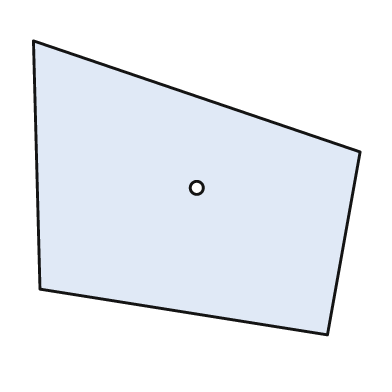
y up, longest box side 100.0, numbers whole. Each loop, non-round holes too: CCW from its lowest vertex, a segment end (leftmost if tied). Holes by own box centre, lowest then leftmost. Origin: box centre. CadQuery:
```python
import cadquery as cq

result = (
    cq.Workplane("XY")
    .moveTo(40.0, -45.0)
    .lineTo(50.0, 11.0)
    .lineTo(-50.0, 45.0)
    .lineTo(-48.0, -31.0)
    .close()
    .moveTo(0.0, 0.0)
    .circle(2.0)
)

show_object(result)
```